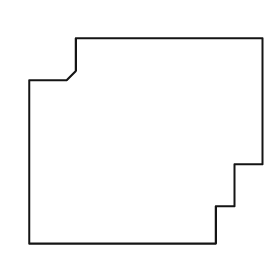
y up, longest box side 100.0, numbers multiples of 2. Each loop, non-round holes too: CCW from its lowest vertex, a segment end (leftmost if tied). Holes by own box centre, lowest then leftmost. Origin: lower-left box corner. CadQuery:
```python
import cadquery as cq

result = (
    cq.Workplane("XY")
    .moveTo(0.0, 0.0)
    .lineTo(80.0, 0.0)
    .lineTo(80.0, 16.0)
    .lineTo(88.0, 16.0)
    .lineTo(88.0, 34.0)
    .lineTo(100.0, 34.0)
    .lineTo(100.0, 88.0)
    .lineTo(20.0, 88.0)
    .lineTo(20.0, 74.0)
    .lineTo(16.0, 70.0)
    .lineTo(0.0, 70.0)
    .close()
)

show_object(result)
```